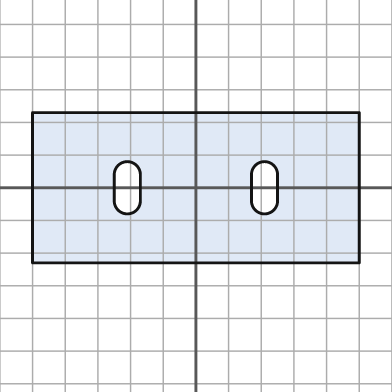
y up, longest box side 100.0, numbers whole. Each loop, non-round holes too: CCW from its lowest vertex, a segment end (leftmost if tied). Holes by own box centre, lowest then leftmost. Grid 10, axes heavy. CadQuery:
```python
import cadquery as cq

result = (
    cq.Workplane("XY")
    .moveTo(-50.0, -23.0)
    .lineTo(50.0, -23.0)
    .lineTo(50.0, 23.0)
    .lineTo(-50.0, 23.0)
    .close()
    .moveTo(-25.0, -4.0)
    .threePointArc((-21.0, -8.0), (-17.0, -4.0))
    .lineTo(-17.0, 4.0)
    .threePointArc((-21.0, 8.0), (-25.0, 4.0))
    .close()
    .moveTo(17.0, -4.0)
    .threePointArc((21.0, -8.0), (25.0, -4.0))
    .lineTo(25.0, 4.0)
    .threePointArc((21.0, 8.0), (17.0, 4.0))
    .close()
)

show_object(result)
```